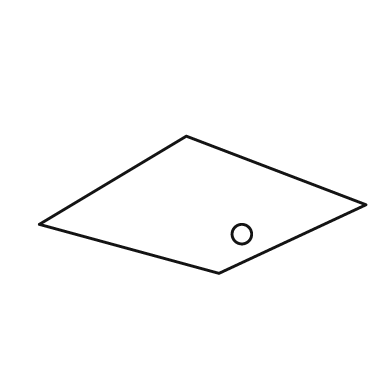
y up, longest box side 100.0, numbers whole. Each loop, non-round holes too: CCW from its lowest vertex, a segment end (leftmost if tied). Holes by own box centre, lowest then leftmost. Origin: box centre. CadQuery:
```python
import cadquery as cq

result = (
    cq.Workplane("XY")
    .moveTo(5.0, -21.0)
    .lineTo(50.0, 0.0)
    .lineTo(-5.0, 21.0)
    .lineTo(-50.0, -6.0)
    .close()
    .moveTo(12.0, -9.0)
    .circle(3.0)
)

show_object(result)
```